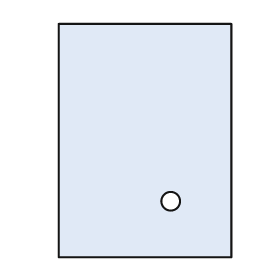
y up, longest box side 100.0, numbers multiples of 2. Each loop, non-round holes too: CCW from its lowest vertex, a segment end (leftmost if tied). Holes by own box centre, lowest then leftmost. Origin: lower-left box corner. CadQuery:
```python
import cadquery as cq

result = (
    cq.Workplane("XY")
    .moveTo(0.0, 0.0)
    .lineTo(74.0, 0.0)
    .lineTo(74.0, 100.0)
    .lineTo(0.0, 100.0)
    .close()
    .moveTo(48.0, 24.0)
    .circle(4.0)
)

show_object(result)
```